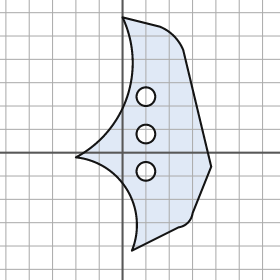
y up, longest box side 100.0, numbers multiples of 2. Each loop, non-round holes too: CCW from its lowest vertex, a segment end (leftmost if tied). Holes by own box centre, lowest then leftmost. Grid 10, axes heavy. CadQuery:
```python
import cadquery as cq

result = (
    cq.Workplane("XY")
    .moveTo(4.0, -42.0)
    .lineTo(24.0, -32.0)
    .threePointArc((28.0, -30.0), (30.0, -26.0))
    .lineTo(38.0, -6.0)
    .lineTo(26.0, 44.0)
    .threePointArc((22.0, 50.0), (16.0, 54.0))
    .lineTo(0.0, 58.0)
    .threePointArc((2.0, 24.0), (-20.0, -2.0))
    .threePointArc((2.0, -16.0), (4.0, -42.0))
    .close()
    .moveTo(10.0, -8.0)
    .circle(4.0)
    .moveTo(10.0, 8.0)
    .circle(4.0)
    .moveTo(10.0, 24.0)
    .circle(4.0)
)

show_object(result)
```